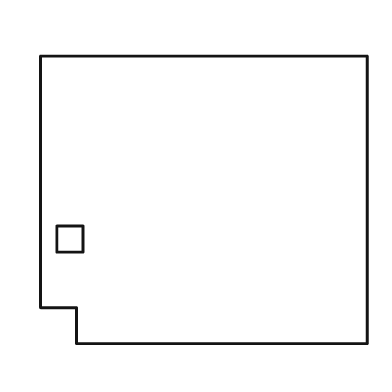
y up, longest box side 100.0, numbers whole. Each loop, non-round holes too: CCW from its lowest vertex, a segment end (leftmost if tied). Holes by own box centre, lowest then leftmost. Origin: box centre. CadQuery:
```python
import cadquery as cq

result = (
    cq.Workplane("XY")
    .moveTo(-39.0, -44.0)
    .lineTo(50.0, -44.0)
    .lineTo(50.0, 44.0)
    .lineTo(-50.0, 44.0)
    .lineTo(-50.0, -33.0)
    .lineTo(-39.0, -33.0)
    .close()
    .moveTo(-45.0, -16.0)
    .lineTo(-37.0, -16.0)
    .lineTo(-37.0, -8.0)
    .lineTo(-45.0, -8.0)
    .close()
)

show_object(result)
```